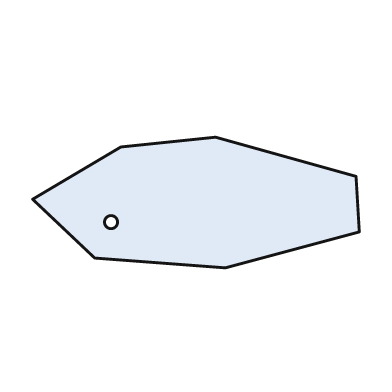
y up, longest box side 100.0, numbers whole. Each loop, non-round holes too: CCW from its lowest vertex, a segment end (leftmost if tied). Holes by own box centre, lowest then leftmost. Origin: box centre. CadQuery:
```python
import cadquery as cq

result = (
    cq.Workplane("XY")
    .moveTo(9.0, -20.0)
    .lineTo(50.0, -9.0)
    .lineTo(49.0, 8.0)
    .lineTo(6.0, 20.0)
    .lineTo(-23.0, 17.0)
    .lineTo(-50.0, 1.0)
    .lineTo(-31.0, -17.0)
    .close()
    .moveTo(-26.0, -6.0)
    .circle(2.0)
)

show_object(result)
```